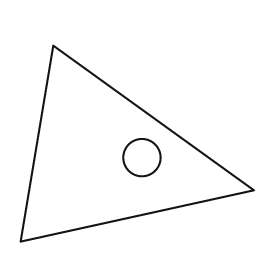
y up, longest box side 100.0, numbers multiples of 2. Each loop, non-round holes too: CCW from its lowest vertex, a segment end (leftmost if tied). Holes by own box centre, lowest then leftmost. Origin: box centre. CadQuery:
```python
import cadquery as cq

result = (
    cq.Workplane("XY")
    .moveTo(-50.0, -42.0)
    .lineTo(50.0, -20.0)
    .lineTo(-36.0, 42.0)
    .close()
    .moveTo(2.0, -6.0)
    .circle(8.0)
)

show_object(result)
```